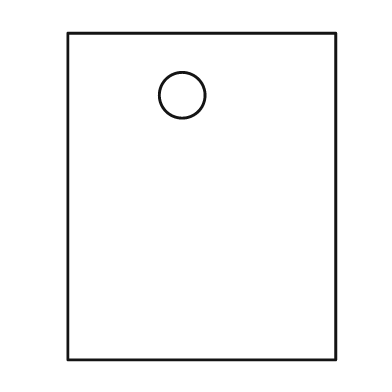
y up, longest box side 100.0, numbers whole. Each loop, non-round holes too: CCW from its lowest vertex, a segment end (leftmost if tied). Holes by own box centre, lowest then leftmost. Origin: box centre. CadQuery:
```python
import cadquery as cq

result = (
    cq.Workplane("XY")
    .moveTo(-41.0, -50.0)
    .lineTo(41.0, -50.0)
    .lineTo(41.0, 50.0)
    .lineTo(-41.0, 50.0)
    .close()
    .moveTo(-6.0, 31.0)
    .circle(7.0)
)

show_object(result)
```